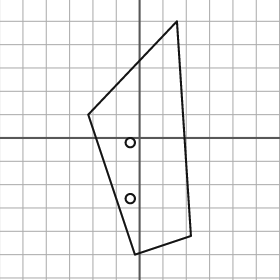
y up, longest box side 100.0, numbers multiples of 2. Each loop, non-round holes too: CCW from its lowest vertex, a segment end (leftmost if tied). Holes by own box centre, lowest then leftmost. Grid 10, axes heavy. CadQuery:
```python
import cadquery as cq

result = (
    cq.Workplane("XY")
    .moveTo(-2.0, -50.0)
    .lineTo(22.0, -42.0)
    .lineTo(16.0, 50.0)
    .lineTo(-22.0, 10.0)
    .close()
    .moveTo(-4.0, -26.0)
    .circle(2.0)
    .moveTo(-4.0, -2.0)
    .circle(2.0)
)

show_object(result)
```